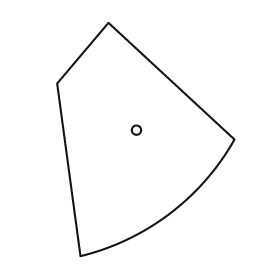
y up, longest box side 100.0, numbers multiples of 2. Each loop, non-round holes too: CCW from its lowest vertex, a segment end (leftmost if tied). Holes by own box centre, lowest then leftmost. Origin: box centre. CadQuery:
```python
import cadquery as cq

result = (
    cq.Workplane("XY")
    .moveTo(-28.0, -50.0)
    .threePointArc((10.0, -32.0), (38.0, 0.0))
    .lineTo(-16.0, 50.0)
    .lineTo(-38.0, 24.0)
    .close()
    .moveTo(-4.0, 4.0)
    .circle(2.0)
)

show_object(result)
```